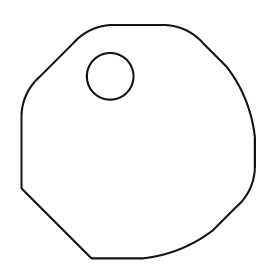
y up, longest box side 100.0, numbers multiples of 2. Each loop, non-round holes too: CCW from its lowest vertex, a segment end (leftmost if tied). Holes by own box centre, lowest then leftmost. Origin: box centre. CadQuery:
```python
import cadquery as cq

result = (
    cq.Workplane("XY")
    .moveTo(-20.0, -50.0)
    .lineTo(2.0, -50.0)
    .threePointArc((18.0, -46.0), (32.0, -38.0))
    .lineTo(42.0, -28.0)
    .threePointArc((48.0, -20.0), (50.0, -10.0))
    .lineTo(50.0, 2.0)
    .threePointArc((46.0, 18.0), (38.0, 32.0))
    .lineTo(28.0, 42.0)
    .threePointArc((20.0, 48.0), (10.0, 50.0))
    .lineTo(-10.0, 50.0)
    .threePointArc((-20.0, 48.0), (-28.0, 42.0))
    .lineTo(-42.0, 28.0)
    .threePointArc((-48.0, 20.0), (-50.0, 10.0))
    .lineTo(-50.0, -20.0)
    .close()
    .moveTo(-12.0, 28.0)
    .circle(10.0)
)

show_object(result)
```